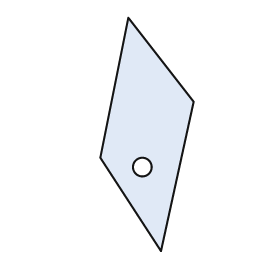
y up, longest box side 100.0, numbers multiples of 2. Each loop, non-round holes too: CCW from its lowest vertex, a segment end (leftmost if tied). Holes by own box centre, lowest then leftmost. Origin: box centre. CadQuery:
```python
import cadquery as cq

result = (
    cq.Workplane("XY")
    .moveTo(6.0, -50.0)
    .lineTo(20.0, 14.0)
    .lineTo(-8.0, 50.0)
    .lineTo(-20.0, -10.0)
    .close()
    .moveTo(-2.0, -14.0)
    .circle(4.0)
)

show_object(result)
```